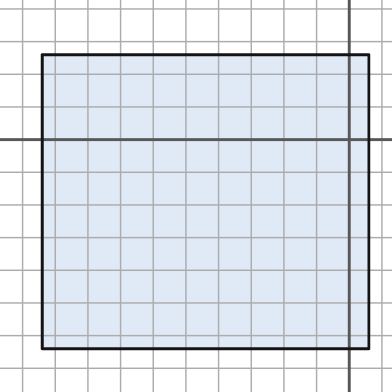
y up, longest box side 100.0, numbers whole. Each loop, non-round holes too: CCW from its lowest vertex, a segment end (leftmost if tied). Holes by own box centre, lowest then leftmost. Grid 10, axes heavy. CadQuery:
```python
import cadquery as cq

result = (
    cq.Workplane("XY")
    .moveTo(-94.0, -64.0)
    .lineTo(6.0, -64.0)
    .lineTo(6.0, 26.0)
    .lineTo(-94.0, 26.0)
    .close()
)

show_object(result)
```